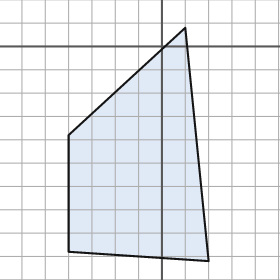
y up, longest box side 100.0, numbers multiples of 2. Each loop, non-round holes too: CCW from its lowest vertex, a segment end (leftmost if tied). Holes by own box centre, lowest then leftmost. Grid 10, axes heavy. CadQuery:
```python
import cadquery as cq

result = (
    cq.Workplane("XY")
    .moveTo(20.0, -92.0)
    .lineTo(10.0, 8.0)
    .lineTo(-40.0, -38.0)
    .lineTo(-40.0, -88.0)
    .close()
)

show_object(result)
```